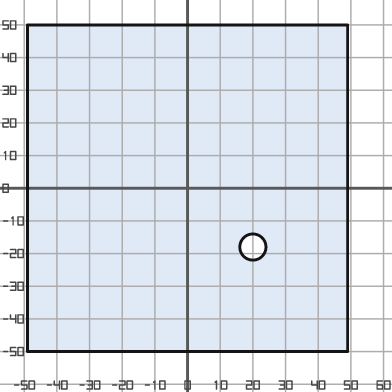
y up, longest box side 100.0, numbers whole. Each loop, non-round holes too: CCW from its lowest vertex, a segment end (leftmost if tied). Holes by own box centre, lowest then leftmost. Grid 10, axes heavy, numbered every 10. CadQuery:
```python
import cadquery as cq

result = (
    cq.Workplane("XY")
    .moveTo(-49.0, -50.0)
    .lineTo(49.0, -50.0)
    .lineTo(49.0, 50.0)
    .lineTo(-49.0, 50.0)
    .close()
    .moveTo(20.0, -18.0)
    .circle(4.0)
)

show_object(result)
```